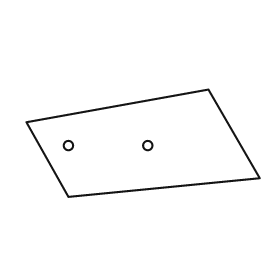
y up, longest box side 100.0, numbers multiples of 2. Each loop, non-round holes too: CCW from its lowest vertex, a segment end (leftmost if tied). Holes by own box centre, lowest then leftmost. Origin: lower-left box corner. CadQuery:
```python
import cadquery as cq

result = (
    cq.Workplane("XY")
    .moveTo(18.0, 0.0)
    .lineTo(100.0, 8.0)
    .lineTo(78.0, 46.0)
    .lineTo(0.0, 32.0)
    .close()
    .moveTo(18.0, 22.0)
    .circle(2.0)
    .moveTo(52.0, 22.0)
    .circle(2.0)
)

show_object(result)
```